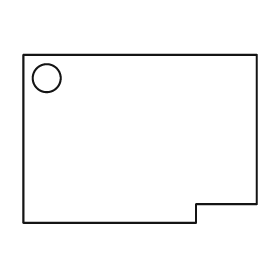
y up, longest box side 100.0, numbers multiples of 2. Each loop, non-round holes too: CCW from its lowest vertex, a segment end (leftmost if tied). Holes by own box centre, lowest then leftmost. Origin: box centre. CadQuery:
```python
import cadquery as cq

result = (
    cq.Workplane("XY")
    .moveTo(-50.0, -36.0)
    .lineTo(24.0, -36.0)
    .lineTo(24.0, -28.0)
    .lineTo(50.0, -28.0)
    .lineTo(50.0, 36.0)
    .lineTo(-50.0, 36.0)
    .close()
    .moveTo(-40.0, 26.0)
    .circle(6.0)
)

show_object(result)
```